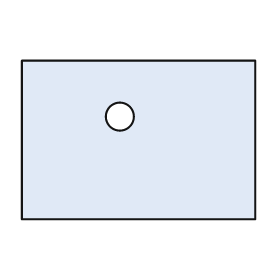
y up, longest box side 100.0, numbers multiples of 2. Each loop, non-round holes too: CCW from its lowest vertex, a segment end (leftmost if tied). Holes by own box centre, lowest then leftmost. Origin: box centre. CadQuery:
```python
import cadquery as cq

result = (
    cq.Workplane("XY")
    .moveTo(-50.0, -34.0)
    .lineTo(50.0, -34.0)
    .lineTo(50.0, 34.0)
    .lineTo(-50.0, 34.0)
    .close()
    .moveTo(-8.0, 10.0)
    .circle(6.0)
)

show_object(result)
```